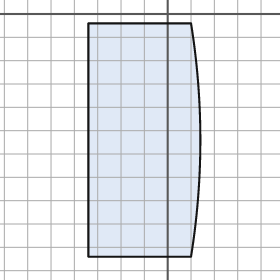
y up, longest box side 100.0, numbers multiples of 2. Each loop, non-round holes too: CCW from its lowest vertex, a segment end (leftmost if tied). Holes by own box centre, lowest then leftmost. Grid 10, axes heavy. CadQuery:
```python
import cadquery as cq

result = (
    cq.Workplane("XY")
    .moveTo(-34.0, -104.0)
    .lineTo(10.0, -104.0)
    .threePointArc((14.0, -54.0), (10.0, -4.0))
    .lineTo(-34.0, -4.0)
    .close()
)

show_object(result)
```